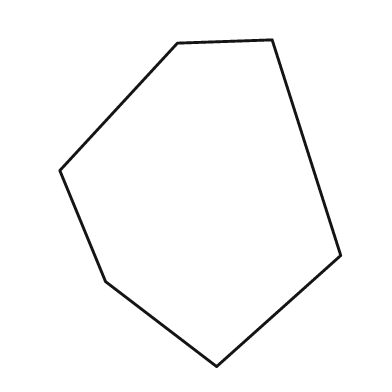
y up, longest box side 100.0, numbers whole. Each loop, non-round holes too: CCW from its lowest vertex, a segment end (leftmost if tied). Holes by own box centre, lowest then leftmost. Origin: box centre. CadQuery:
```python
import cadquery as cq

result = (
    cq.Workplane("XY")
    .moveTo(5.0, -50.0)
    .lineTo(43.0, -16.0)
    .lineTo(22.0, 50.0)
    .lineTo(-7.0, 49.0)
    .lineTo(-43.0, 10.0)
    .lineTo(-29.0, -24.0)
    .close()
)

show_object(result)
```